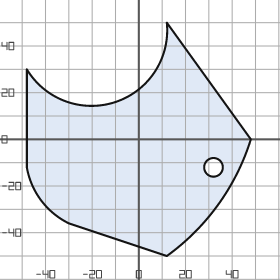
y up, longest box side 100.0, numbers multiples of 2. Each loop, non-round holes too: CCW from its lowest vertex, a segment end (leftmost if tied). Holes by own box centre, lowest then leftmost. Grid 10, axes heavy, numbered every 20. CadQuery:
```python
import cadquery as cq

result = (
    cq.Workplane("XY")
    .moveTo(12.0, -50.0)
    .threePointArc((34.0, -28.0), (48.0, 0.0))
    .lineTo(12.0, 50.0)
    .threePointArc((-10.0, 16.0), (-48.0, 30.0))
    .lineTo(-48.0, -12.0)
    .threePointArc((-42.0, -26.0), (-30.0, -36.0))
    .close()
    .moveTo(32.0, -12.0)
    .circle(4.0)
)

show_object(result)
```